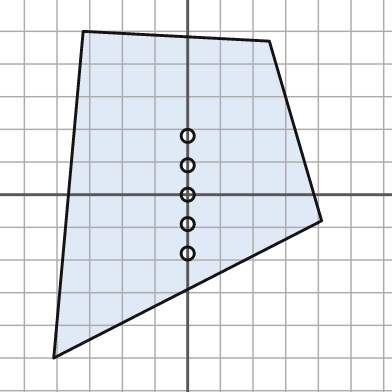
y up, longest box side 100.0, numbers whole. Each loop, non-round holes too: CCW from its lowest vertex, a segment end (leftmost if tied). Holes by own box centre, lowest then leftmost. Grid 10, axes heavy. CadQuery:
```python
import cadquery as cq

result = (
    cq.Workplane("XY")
    .moveTo(-41.0, -50.0)
    .lineTo(41.0, -8.0)
    .lineTo(25.0, 47.0)
    .lineTo(-32.0, 50.0)
    .close()
    .moveTo(0.0, -18.0)
    .circle(2.0)
    .moveTo(0.0, -9.0)
    .circle(2.0)
    .moveTo(0.0, 0.0)
    .circle(2.0)
    .moveTo(0.0, 9.0)
    .circle(2.0)
    .moveTo(0.0, 18.0)
    .circle(2.0)
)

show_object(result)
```